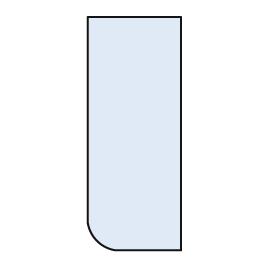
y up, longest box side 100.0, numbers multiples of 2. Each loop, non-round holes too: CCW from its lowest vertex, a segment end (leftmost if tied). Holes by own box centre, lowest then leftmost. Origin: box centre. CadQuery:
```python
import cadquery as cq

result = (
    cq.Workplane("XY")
    .moveTo(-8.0, -50.0)
    .lineTo(20.0, -50.0)
    .lineTo(20.0, 50.0)
    .lineTo(-20.0, 50.0)
    .lineTo(-20.0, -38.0)
    .threePointArc((-16.0, -46.0), (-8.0, -50.0))
    .close()
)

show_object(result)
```